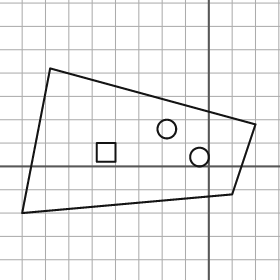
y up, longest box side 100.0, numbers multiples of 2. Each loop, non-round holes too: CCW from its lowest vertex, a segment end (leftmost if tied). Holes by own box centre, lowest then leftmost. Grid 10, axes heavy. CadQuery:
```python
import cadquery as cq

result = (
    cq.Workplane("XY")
    .moveTo(-80.0, -20.0)
    .lineTo(10.0, -12.0)
    .lineTo(20.0, 18.0)
    .lineTo(-68.0, 42.0)
    .close()
    .moveTo(-4.0, 4.0)
    .circle(4.0)
    .moveTo(-48.0, 2.0)
    .lineTo(-40.0, 2.0)
    .lineTo(-40.0, 10.0)
    .lineTo(-48.0, 10.0)
    .close()
    .moveTo(-18.0, 16.0)
    .circle(4.0)
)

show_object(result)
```